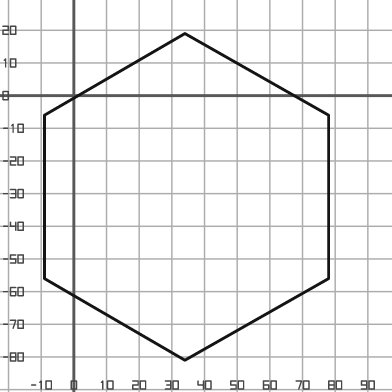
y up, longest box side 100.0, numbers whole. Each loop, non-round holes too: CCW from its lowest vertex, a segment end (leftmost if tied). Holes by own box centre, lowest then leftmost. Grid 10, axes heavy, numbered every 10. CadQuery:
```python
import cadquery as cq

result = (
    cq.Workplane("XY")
    .moveTo(34.0, -81.0)
    .lineTo(78.0, -56.0)
    .lineTo(78.0, -6.0)
    .lineTo(34.0, 19.0)
    .lineTo(-9.0, -6.0)
    .lineTo(-9.0, -56.0)
    .close()
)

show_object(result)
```